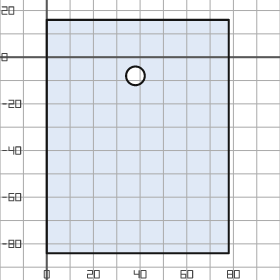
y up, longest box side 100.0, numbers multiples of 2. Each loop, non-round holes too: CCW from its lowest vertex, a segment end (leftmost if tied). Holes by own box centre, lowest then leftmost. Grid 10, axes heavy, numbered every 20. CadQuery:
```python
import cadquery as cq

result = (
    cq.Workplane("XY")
    .moveTo(0.0, -84.0)
    .lineTo(78.0, -84.0)
    .lineTo(78.0, 16.0)
    .lineTo(0.0, 16.0)
    .close()
    .moveTo(38.0, -8.0)
    .circle(4.0)
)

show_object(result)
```